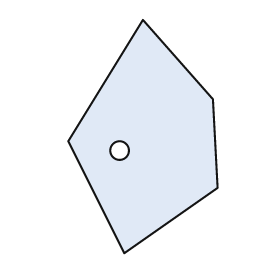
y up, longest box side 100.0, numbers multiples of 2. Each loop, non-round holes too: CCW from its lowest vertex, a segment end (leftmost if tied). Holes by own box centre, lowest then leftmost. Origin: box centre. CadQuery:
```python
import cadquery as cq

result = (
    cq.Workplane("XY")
    .moveTo(-8.0, -50.0)
    .lineTo(32.0, -22.0)
    .lineTo(30.0, 16.0)
    .lineTo(0.0, 50.0)
    .lineTo(-32.0, -2.0)
    .close()
    .moveTo(-10.0, -6.0)
    .circle(4.0)
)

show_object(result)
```